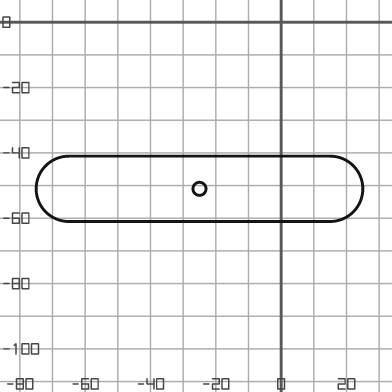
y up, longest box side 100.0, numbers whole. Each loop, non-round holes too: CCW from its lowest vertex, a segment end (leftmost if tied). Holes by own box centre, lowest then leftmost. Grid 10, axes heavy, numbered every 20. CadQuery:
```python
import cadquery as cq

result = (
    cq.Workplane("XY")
    .moveTo(-65.0, -61.0)
    .lineTo(15.0, -61.0)
    .threePointArc((25.0, -51.0), (15.0, -41.0))
    .lineTo(-65.0, -41.0)
    .threePointArc((-75.0, -51.0), (-65.0, -61.0))
    .close()
    .moveTo(-25.0, -51.0)
    .circle(2.0)
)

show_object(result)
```